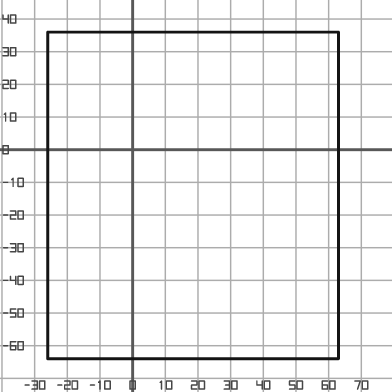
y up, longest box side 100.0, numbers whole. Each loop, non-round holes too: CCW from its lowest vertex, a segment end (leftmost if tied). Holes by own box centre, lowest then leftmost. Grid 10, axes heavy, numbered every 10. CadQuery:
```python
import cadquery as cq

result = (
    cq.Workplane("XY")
    .moveTo(-26.0, -64.0)
    .lineTo(63.0, -64.0)
    .lineTo(63.0, 36.0)
    .lineTo(-26.0, 36.0)
    .close()
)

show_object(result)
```